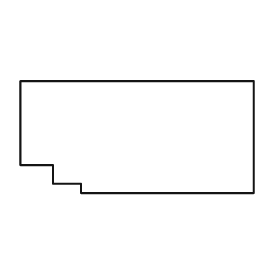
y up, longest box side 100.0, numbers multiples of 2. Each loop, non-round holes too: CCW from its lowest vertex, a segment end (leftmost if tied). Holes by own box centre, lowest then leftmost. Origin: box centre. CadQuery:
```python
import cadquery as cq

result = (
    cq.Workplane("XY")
    .moveTo(-24.0, -24.0)
    .lineTo(50.0, -24.0)
    .lineTo(50.0, 24.0)
    .lineTo(-50.0, 24.0)
    .lineTo(-50.0, -12.0)
    .lineTo(-36.0, -12.0)
    .lineTo(-36.0, -20.0)
    .lineTo(-24.0, -20.0)
    .close()
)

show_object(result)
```